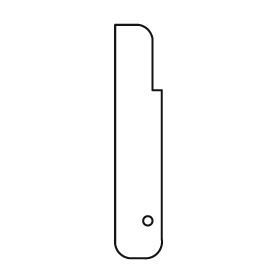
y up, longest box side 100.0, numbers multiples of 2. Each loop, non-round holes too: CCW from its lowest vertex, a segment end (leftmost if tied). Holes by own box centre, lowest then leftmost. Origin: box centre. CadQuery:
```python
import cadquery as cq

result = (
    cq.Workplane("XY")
    .moveTo(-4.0, -50.0)
    .lineTo(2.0, -50.0)
    .threePointArc((8.0, -48.0), (10.0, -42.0))
    .lineTo(10.0, 22.0)
    .lineTo(6.0, 22.0)
    .lineTo(6.0, 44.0)
    .threePointArc((4.0, 48.0), (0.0, 50.0))
    .lineTo(-10.0, 50.0)
    .lineTo(-10.0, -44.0)
    .threePointArc((-8.0, -48.0), (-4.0, -50.0))
    .close()
    .moveTo(4.0, -34.0)
    .circle(2.0)
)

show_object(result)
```